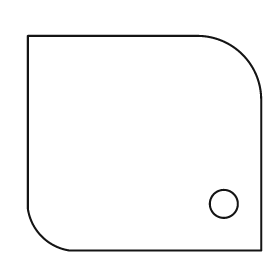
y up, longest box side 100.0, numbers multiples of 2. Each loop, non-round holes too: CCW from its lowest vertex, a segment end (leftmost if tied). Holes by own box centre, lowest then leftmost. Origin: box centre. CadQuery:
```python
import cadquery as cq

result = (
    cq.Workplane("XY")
    .moveTo(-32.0, -46.0)
    .lineTo(50.0, -46.0)
    .lineTo(50.0, 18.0)
    .threePointArc((42.0, 38.0), (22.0, 46.0))
    .lineTo(-50.0, 46.0)
    .lineTo(-50.0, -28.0)
    .threePointArc((-44.0, -40.0), (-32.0, -46.0))
    .close()
    .moveTo(34.0, -26.0)
    .circle(6.0)
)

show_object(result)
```